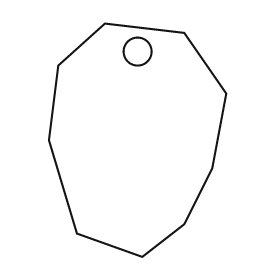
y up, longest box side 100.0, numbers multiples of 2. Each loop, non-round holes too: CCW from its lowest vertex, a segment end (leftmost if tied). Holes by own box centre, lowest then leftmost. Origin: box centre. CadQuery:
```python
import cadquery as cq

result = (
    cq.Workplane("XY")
    .moveTo(2.0, -50.0)
    .lineTo(20.0, -36.0)
    .lineTo(32.0, -12.0)
    .lineTo(38.0, 20.0)
    .lineTo(20.0, 46.0)
    .lineTo(-14.0, 50.0)
    .lineTo(-34.0, 32.0)
    .lineTo(-38.0, 0.0)
    .lineTo(-26.0, -40.0)
    .close()
    .moveTo(0.0, 38.0)
    .circle(6.0)
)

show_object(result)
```